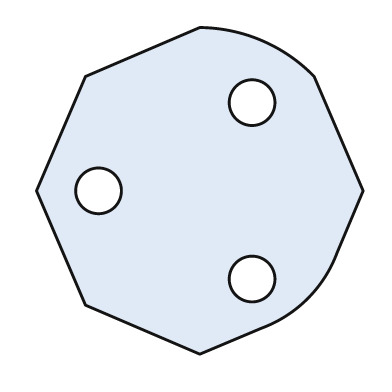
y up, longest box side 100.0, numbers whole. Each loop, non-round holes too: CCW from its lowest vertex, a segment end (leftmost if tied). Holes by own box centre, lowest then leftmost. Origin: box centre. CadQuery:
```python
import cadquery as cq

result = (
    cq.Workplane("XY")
    .moveTo(0.0, -50.0)
    .lineTo(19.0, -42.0)
    .threePointArc((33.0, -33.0), (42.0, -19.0))
    .lineTo(50.0, 0.0)
    .lineTo(35.0, 35.0)
    .threePointArc((19.0, 46.0), (0.0, 50.0))
    .lineTo(-35.0, 35.0)
    .lineTo(-50.0, 0.0)
    .lineTo(-35.0, -35.0)
    .close()
    .moveTo(16.0, -27.0)
    .circle(7.0)
    .moveTo(-31.0, 0.0)
    .circle(7.0)
    .moveTo(16.0, 27.0)
    .circle(7.0)
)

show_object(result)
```